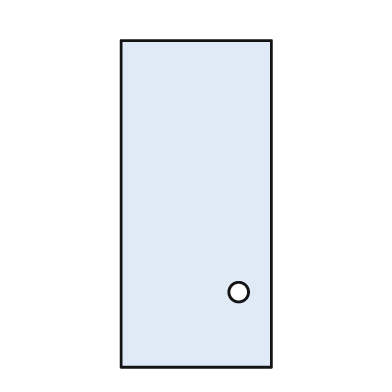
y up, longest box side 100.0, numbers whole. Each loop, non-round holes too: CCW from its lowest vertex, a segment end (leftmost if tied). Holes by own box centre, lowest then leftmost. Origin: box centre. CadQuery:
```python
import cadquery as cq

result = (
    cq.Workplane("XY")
    .moveTo(-23.0, -50.0)
    .lineTo(23.0, -50.0)
    .lineTo(23.0, 50.0)
    .lineTo(-23.0, 50.0)
    .close()
    .moveTo(13.0, -27.0)
    .circle(3.0)
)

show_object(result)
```